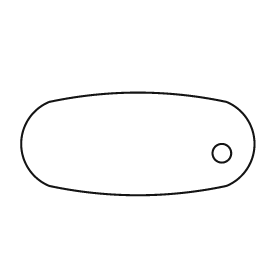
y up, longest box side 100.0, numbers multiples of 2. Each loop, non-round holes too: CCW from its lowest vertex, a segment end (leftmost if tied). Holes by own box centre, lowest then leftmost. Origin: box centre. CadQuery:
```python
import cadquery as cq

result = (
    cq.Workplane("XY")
    .moveTo(-38.0, -18.0)
    .threePointArc((0.0, -22.0), (38.0, -18.0))
    .threePointArc((50.0, 0.0), (38.0, 18.0))
    .threePointArc((0.0, 22.0), (-38.0, 18.0))
    .threePointArc((-50.0, 0.0), (-38.0, -18.0))
    .close()
    .moveTo(36.0, -4.0)
    .circle(4.0)
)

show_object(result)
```